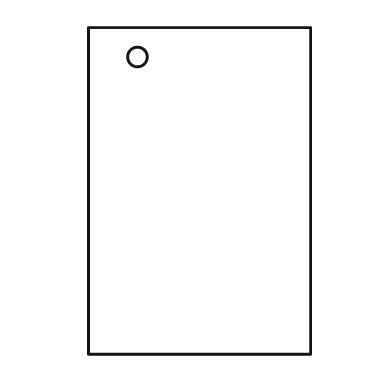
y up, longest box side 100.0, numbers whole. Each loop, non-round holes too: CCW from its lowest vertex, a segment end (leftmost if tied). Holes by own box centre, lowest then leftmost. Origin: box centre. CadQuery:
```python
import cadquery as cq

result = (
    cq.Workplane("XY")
    .moveTo(-34.0, -50.0)
    .lineTo(34.0, -50.0)
    .lineTo(34.0, 50.0)
    .lineTo(-34.0, 50.0)
    .close()
    .moveTo(-19.0, 41.0)
    .circle(3.0)
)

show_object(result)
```